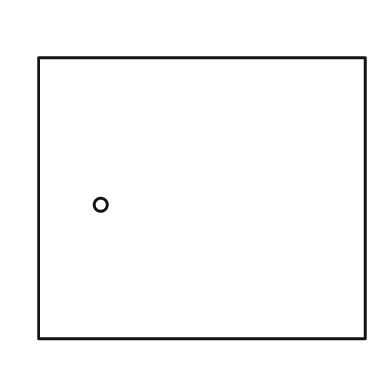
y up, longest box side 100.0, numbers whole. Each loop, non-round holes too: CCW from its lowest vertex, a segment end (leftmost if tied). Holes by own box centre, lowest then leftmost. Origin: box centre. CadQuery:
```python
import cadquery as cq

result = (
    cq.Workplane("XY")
    .moveTo(-50.0, -43.0)
    .lineTo(50.0, -43.0)
    .lineTo(50.0, 43.0)
    .lineTo(-50.0, 43.0)
    .close()
    .moveTo(-31.0, -2.0)
    .circle(2.0)
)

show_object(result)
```